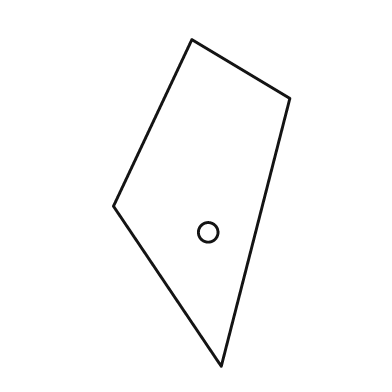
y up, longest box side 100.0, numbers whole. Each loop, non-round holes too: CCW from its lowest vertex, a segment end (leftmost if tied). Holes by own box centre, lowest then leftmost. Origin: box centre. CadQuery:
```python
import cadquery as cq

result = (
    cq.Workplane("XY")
    .moveTo(6.0, -50.0)
    .lineTo(27.0, 32.0)
    .lineTo(-3.0, 50.0)
    .lineTo(-27.0, -1.0)
    .close()
    .moveTo(2.0, -9.0)
    .circle(3.0)
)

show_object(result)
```